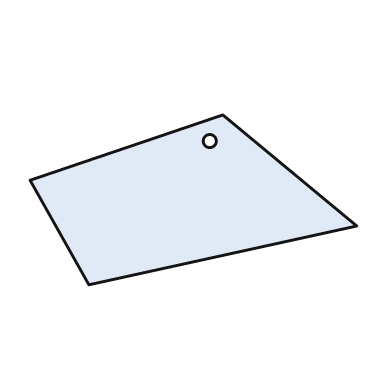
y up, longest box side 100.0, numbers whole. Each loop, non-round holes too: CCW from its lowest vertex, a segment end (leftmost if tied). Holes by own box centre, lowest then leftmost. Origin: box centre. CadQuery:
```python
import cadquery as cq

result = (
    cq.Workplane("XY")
    .moveTo(-32.0, -26.0)
    .lineTo(50.0, -8.0)
    .lineTo(9.0, 26.0)
    .lineTo(-50.0, 6.0)
    .close()
    .moveTo(5.0, 18.0)
    .circle(2.0)
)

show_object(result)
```